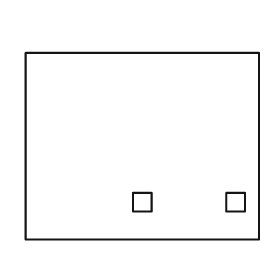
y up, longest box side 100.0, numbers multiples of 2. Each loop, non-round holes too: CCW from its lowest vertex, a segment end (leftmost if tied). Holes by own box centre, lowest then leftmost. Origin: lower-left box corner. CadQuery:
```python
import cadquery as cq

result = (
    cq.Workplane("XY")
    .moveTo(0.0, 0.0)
    .lineTo(100.0, 0.0)
    .lineTo(100.0, 80.0)
    .lineTo(0.0, 80.0)
    .close()
    .moveTo(46.0, 12.0)
    .lineTo(54.0, 12.0)
    .lineTo(54.0, 20.0)
    .lineTo(46.0, 20.0)
    .close()
    .moveTo(86.0, 12.0)
    .lineTo(94.0, 12.0)
    .lineTo(94.0, 20.0)
    .lineTo(86.0, 20.0)
    .close()
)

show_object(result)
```